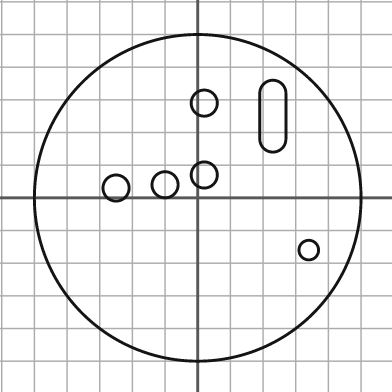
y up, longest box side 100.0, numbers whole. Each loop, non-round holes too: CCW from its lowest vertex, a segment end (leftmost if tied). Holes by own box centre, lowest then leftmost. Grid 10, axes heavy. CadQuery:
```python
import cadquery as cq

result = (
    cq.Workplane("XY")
    .moveTo(0.0, 0.0)
    .circle(50.0)
    .moveTo(34.0, -16.0)
    .circle(3.0)
    .moveTo(-25.0, 3.0)
    .circle(4.0)
    .moveTo(-10.0, 4.0)
    .circle(4.0)
    .moveTo(2.0, 7.0)
    .circle(4.0)
    .moveTo(19.0, 18.0)
    .threePointArc((23.0, 14.0), (27.0, 18.0))
    .lineTo(27.0, 32.0)
    .threePointArc((23.0, 36.0), (19.0, 32.0))
    .close()
    .moveTo(2.0, 29.0)
    .circle(4.0)
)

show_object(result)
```